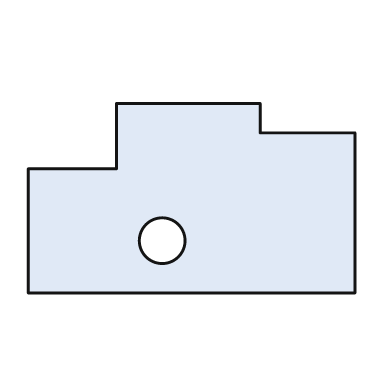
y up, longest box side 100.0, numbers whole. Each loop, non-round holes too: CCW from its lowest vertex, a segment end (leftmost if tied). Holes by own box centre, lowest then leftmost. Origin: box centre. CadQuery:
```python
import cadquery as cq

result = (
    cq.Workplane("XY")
    .moveTo(-50.0, -29.0)
    .lineTo(50.0, -29.0)
    .lineTo(50.0, 20.0)
    .lineTo(21.0, 20.0)
    .lineTo(21.0, 29.0)
    .lineTo(-23.0, 29.0)
    .lineTo(-23.0, 9.0)
    .lineTo(-50.0, 9.0)
    .close()
    .moveTo(-9.0, -13.0)
    .circle(7.0)
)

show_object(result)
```